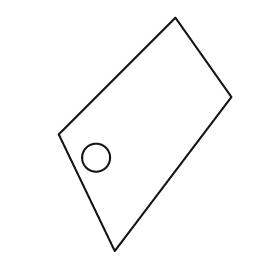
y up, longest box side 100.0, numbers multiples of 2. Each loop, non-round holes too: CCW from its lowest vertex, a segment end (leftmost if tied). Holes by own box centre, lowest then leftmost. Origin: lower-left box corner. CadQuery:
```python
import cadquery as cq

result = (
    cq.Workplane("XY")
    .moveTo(24.0, 0.0)
    .lineTo(74.0, 66.0)
    .lineTo(50.0, 100.0)
    .lineTo(0.0, 50.0)
    .close()
    .moveTo(16.0, 40.0)
    .circle(6.0)
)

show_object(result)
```